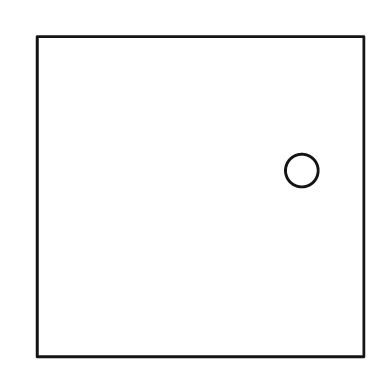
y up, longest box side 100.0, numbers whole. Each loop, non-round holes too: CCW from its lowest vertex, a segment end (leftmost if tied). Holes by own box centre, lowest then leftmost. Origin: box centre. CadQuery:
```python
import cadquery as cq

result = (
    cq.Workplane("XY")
    .moveTo(-50.0, -49.0)
    .lineTo(50.0, -49.0)
    .lineTo(50.0, 49.0)
    .lineTo(-50.0, 49.0)
    .close()
    .moveTo(31.0, 8.0)
    .circle(5.0)
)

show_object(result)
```